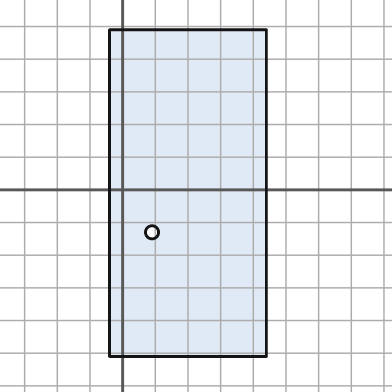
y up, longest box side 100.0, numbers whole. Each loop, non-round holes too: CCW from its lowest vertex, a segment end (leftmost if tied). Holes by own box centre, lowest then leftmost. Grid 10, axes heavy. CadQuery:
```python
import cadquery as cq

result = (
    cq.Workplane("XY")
    .moveTo(-4.0, -51.0)
    .lineTo(44.0, -51.0)
    .lineTo(44.0, 49.0)
    .lineTo(-4.0, 49.0)
    .close()
    .moveTo(9.0, -13.0)
    .circle(2.0)
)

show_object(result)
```